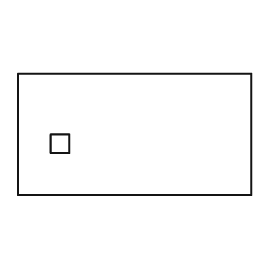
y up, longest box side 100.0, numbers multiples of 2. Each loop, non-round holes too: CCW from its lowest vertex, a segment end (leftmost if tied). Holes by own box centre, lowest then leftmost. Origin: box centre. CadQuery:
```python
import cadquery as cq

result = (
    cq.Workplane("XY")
    .moveTo(-50.0, -26.0)
    .lineTo(50.0, -26.0)
    .lineTo(50.0, 26.0)
    .lineTo(-50.0, 26.0)
    .close()
    .moveTo(-36.0, -8.0)
    .lineTo(-28.0, -8.0)
    .lineTo(-28.0, 0.0)
    .lineTo(-36.0, 0.0)
    .close()
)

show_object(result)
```